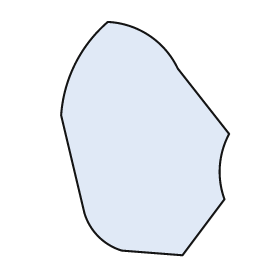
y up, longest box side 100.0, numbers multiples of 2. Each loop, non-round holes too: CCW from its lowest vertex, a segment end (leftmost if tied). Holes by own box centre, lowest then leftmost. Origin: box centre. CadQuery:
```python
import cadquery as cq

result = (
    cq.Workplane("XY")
    .moveTo(16.0, -50.0)
    .lineTo(34.0, -26.0)
    .threePointArc((32.0, -12.0), (36.0, 2.0))
    .lineTo(14.0, 30.0)
    .threePointArc((2.0, 44.0), (-16.0, 50.0))
    .threePointArc((-30.0, 32.0), (-36.0, 10.0))
    .lineTo(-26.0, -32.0)
    .threePointArc((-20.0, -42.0), (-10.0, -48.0))
    .close()
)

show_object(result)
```